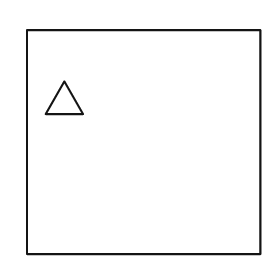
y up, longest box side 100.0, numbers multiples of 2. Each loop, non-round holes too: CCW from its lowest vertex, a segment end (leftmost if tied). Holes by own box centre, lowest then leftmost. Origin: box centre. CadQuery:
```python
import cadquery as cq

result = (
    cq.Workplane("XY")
    .moveTo(-50.0, -48.0)
    .lineTo(50.0, -48.0)
    .lineTo(50.0, 48.0)
    .lineTo(-50.0, 48.0)
    .close()
    .moveTo(-42.0, 12.0)
    .lineTo(-26.0, 12.0)
    .lineTo(-34.0, 26.0)
    .close()
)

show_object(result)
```